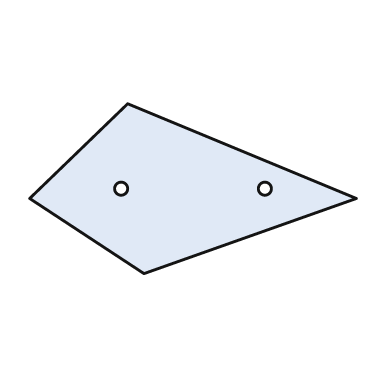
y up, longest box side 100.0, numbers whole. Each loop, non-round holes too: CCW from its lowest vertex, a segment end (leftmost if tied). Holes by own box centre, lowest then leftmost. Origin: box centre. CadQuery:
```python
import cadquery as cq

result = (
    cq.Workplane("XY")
    .moveTo(-15.0, -26.0)
    .lineTo(50.0, -3.0)
    .lineTo(-20.0, 26.0)
    .lineTo(-50.0, -3.0)
    .close()
    .moveTo(-22.0, 0.0)
    .circle(2.0)
    .moveTo(22.0, 0.0)
    .circle(2.0)
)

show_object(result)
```